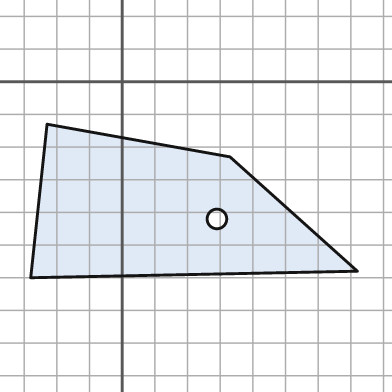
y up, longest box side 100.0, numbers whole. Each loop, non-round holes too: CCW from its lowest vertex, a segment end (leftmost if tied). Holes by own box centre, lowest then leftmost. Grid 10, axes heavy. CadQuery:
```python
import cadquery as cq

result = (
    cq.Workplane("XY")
    .moveTo(-28.0, -60.0)
    .lineTo(72.0, -58.0)
    .lineTo(33.0, -23.0)
    .lineTo(-23.0, -13.0)
    .close()
    .moveTo(29.0, -42.0)
    .circle(3.0)
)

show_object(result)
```